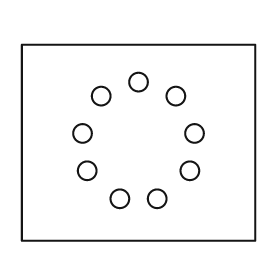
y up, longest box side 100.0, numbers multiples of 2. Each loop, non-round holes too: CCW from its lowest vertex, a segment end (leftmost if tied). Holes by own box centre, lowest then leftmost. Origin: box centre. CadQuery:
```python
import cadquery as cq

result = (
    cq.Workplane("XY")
    .moveTo(-50.0, -42.0)
    .lineTo(50.0, -42.0)
    .lineTo(50.0, 42.0)
    .lineTo(-50.0, 42.0)
    .close()
    .moveTo(-8.0, -24.0)
    .circle(4.0)
    .moveTo(8.0, -24.0)
    .circle(4.0)
    .moveTo(-22.0, -12.0)
    .circle(4.0)
    .moveTo(22.0, -12.0)
    .circle(4.0)
    .moveTo(-24.0, 4.0)
    .circle(4.0)
    .moveTo(24.0, 4.0)
    .circle(4.0)
    .moveTo(-16.0, 20.0)
    .circle(4.0)
    .moveTo(16.0, 20.0)
    .circle(4.0)
    .moveTo(0.0, 26.0)
    .circle(4.0)
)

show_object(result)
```